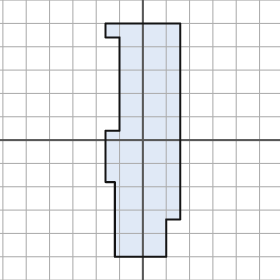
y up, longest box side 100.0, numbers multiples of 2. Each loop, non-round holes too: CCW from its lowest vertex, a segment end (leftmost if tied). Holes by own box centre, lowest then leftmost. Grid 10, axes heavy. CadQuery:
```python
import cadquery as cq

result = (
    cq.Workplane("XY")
    .moveTo(-12.0, -50.0)
    .lineTo(10.0, -50.0)
    .lineTo(10.0, -34.0)
    .lineTo(16.0, -34.0)
    .lineTo(16.0, 50.0)
    .lineTo(-16.0, 50.0)
    .lineTo(-16.0, 44.0)
    .lineTo(-10.0, 44.0)
    .lineTo(-10.0, 4.0)
    .lineTo(-16.0, 4.0)
    .lineTo(-16.0, -18.0)
    .lineTo(-12.0, -18.0)
    .close()
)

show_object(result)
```